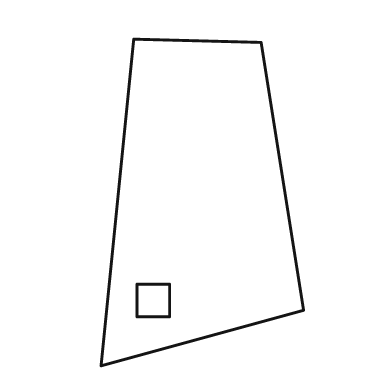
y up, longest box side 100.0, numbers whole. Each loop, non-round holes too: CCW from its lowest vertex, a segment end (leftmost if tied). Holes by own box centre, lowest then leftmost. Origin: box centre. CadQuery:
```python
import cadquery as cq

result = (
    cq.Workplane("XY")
    .moveTo(-31.0, -50.0)
    .lineTo(31.0, -33.0)
    .lineTo(18.0, 49.0)
    .lineTo(-21.0, 50.0)
    .close()
    .moveTo(-20.0, -35.0)
    .lineTo(-10.0, -35.0)
    .lineTo(-10.0, -25.0)
    .lineTo(-20.0, -25.0)
    .close()
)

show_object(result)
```